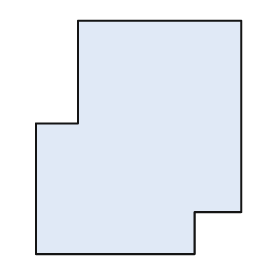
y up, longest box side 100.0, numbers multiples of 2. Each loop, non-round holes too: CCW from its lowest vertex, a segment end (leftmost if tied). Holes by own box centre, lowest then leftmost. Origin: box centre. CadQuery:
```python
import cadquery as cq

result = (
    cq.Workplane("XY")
    .moveTo(-44.0, -50.0)
    .lineTo(24.0, -50.0)
    .lineTo(24.0, -32.0)
    .lineTo(44.0, -32.0)
    .lineTo(44.0, 50.0)
    .lineTo(-26.0, 50.0)
    .lineTo(-26.0, 6.0)
    .lineTo(-44.0, 6.0)
    .close()
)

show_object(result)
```